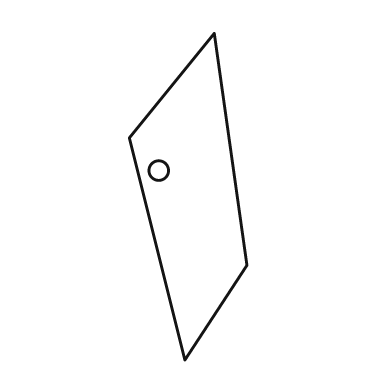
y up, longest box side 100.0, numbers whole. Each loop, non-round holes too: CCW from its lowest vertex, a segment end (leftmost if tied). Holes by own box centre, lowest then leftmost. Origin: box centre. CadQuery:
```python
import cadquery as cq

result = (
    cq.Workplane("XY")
    .moveTo(-1.0, -50.0)
    .lineTo(18.0, -21.0)
    .lineTo(8.0, 50.0)
    .lineTo(-18.0, 18.0)
    .close()
    .moveTo(-9.0, 8.0)
    .circle(3.0)
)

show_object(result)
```